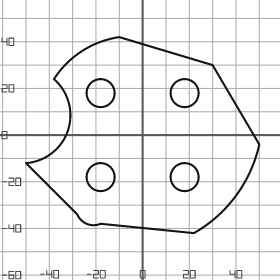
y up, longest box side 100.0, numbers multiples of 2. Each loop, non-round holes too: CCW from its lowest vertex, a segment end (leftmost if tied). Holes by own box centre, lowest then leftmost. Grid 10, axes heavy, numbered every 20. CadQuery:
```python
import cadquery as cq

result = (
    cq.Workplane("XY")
    .moveTo(22.0, -42.0)
    .threePointArc((40.0, -26.0), (50.0, -4.0))
    .lineTo(30.0, 30.0)
    .lineTo(-10.0, 42.0)
    .threePointArc((-26.0, 36.0), (-38.0, 24.0))
    .threePointArc((-32.0, 2.0), (-50.0, -12.0))
    .lineTo(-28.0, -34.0)
    .threePointArc((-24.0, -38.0), (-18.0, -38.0))
    .close()
    .moveTo(-18.0, -18.0)
    .circle(6.0)
    .moveTo(18.0, -18.0)
    .circle(6.0)
    .moveTo(-18.0, 18.0)
    .circle(6.0)
    .moveTo(18.0, 18.0)
    .circle(6.0)
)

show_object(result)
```